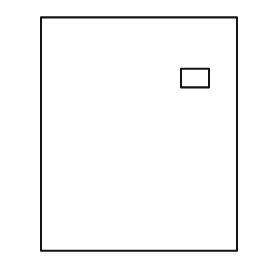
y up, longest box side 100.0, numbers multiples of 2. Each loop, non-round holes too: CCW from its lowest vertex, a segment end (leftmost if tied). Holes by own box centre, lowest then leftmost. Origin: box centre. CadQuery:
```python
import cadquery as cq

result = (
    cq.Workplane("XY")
    .moveTo(-42.0, -50.0)
    .lineTo(42.0, -50.0)
    .lineTo(42.0, 50.0)
    .lineTo(-42.0, 50.0)
    .close()
    .moveTo(18.0, 20.0)
    .lineTo(30.0, 20.0)
    .lineTo(30.0, 28.0)
    .lineTo(18.0, 28.0)
    .close()
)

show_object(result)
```